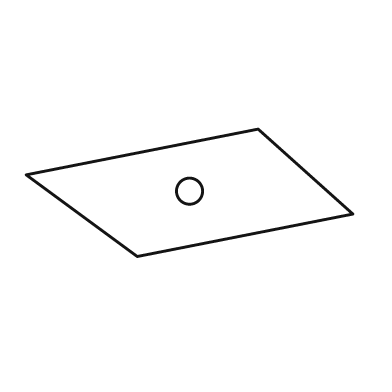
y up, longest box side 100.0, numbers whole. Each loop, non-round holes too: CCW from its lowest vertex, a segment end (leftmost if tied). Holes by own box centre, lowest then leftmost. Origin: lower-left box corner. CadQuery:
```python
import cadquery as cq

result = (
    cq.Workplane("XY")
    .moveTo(34.0, 0.0)
    .lineTo(100.0, 13.0)
    .lineTo(71.0, 39.0)
    .lineTo(0.0, 25.0)
    .close()
    .moveTo(50.0, 20.0)
    .circle(4.0)
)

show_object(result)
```